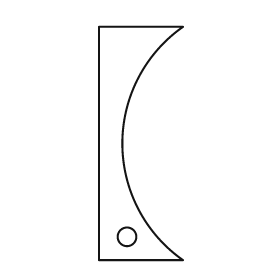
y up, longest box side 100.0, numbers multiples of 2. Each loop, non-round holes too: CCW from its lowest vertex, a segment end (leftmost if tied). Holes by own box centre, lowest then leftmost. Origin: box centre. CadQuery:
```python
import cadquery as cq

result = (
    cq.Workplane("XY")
    .moveTo(-18.0, -50.0)
    .lineTo(18.0, -50.0)
    .threePointArc((-8.0, 0.0), (18.0, 50.0))
    .lineTo(-18.0, 50.0)
    .close()
    .moveTo(-6.0, -40.0)
    .circle(4.0)
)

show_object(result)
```